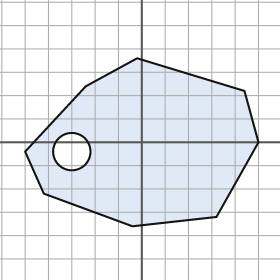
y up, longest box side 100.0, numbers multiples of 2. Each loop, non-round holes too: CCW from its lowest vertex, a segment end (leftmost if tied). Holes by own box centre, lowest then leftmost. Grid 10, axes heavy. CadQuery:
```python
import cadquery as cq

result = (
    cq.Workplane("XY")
    .moveTo(-4.0, -36.0)
    .lineTo(32.0, -32.0)
    .lineTo(50.0, 0.0)
    .lineTo(44.0, 22.0)
    .lineTo(-2.0, 36.0)
    .lineTo(-24.0, 24.0)
    .lineTo(-50.0, -4.0)
    .lineTo(-42.0, -22.0)
    .close()
    .moveTo(-30.0, -4.0)
    .circle(8.0)
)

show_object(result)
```